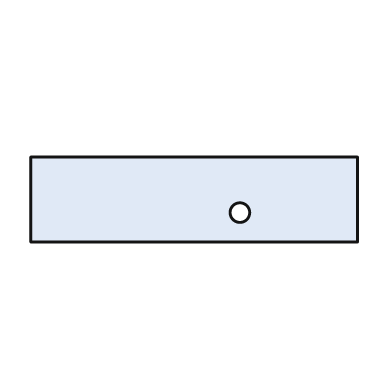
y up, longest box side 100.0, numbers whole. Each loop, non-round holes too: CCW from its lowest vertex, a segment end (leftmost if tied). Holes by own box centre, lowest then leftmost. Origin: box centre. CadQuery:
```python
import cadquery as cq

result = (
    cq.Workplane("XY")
    .moveTo(-50.0, -13.0)
    .lineTo(50.0, -13.0)
    .lineTo(50.0, 13.0)
    .lineTo(-50.0, 13.0)
    .close()
    .moveTo(14.0, -4.0)
    .circle(3.0)
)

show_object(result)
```